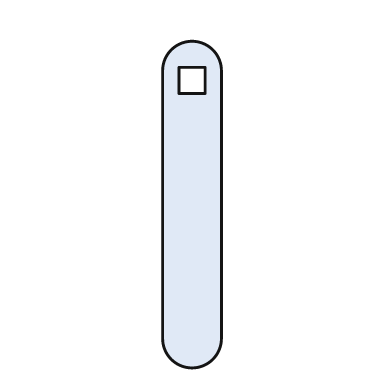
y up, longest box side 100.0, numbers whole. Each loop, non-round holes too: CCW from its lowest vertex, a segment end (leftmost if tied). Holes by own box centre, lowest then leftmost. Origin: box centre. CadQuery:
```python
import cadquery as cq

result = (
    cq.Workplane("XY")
    .moveTo(-9.0, -41.0)
    .threePointArc((0.0, -50.0), (9.0, -41.0))
    .lineTo(9.0, 41.0)
    .threePointArc((0.0, 50.0), (-9.0, 41.0))
    .close()
    .moveTo(-4.0, 34.0)
    .lineTo(4.0, 34.0)
    .lineTo(4.0, 42.0)
    .lineTo(-4.0, 42.0)
    .close()
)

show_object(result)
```